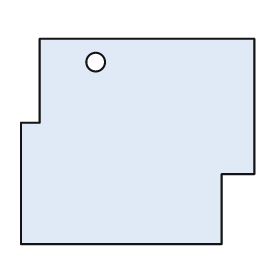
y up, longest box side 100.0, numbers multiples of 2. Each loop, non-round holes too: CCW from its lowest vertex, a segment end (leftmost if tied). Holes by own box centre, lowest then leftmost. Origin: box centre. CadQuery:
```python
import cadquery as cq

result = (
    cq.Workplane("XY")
    .moveTo(-50.0, -44.0)
    .lineTo(36.0, -44.0)
    .lineTo(36.0, -14.0)
    .lineTo(50.0, -14.0)
    .lineTo(50.0, 44.0)
    .lineTo(-42.0, 44.0)
    .lineTo(-42.0, 8.0)
    .lineTo(-50.0, 8.0)
    .close()
    .moveTo(-18.0, 34.0)
    .circle(4.0)
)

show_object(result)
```